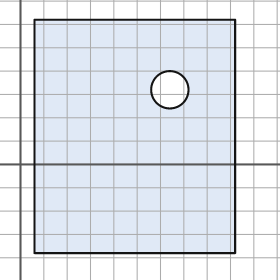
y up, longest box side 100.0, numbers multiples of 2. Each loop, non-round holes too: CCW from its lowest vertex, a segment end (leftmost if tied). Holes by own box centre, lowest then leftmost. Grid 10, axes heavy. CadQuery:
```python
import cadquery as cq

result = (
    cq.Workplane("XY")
    .moveTo(6.0, -38.0)
    .lineTo(92.0, -38.0)
    .lineTo(92.0, 62.0)
    .lineTo(6.0, 62.0)
    .close()
    .moveTo(64.0, 32.0)
    .circle(8.0)
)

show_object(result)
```